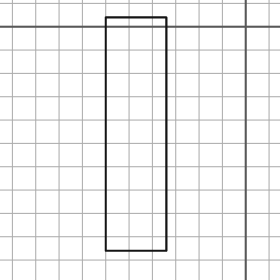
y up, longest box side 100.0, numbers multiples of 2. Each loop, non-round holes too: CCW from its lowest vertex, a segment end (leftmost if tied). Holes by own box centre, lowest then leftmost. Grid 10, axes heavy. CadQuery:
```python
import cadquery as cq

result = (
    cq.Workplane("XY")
    .moveTo(-60.0, -96.0)
    .lineTo(-34.0, -96.0)
    .lineTo(-34.0, 4.0)
    .lineTo(-60.0, 4.0)
    .close()
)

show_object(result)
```